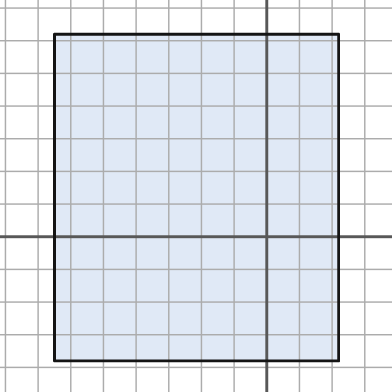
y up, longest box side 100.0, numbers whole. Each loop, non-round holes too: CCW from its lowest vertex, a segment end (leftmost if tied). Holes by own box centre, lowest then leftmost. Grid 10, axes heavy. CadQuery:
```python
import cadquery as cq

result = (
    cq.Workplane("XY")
    .moveTo(-65.0, -38.0)
    .lineTo(22.0, -38.0)
    .lineTo(22.0, 62.0)
    .lineTo(-65.0, 62.0)
    .close()
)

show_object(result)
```